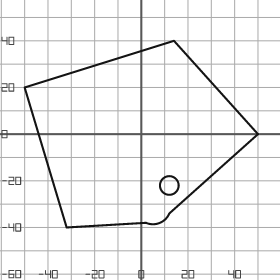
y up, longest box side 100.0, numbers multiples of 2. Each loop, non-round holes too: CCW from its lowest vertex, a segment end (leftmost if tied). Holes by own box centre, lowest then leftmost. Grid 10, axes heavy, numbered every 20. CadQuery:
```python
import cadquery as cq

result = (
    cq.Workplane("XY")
    .moveTo(-32.0, -40.0)
    .lineTo(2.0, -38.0)
    .threePointArc((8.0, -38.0), (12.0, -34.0))
    .lineTo(50.0, 0.0)
    .lineTo(14.0, 40.0)
    .lineTo(-50.0, 20.0)
    .close()
    .moveTo(12.0, -22.0)
    .circle(4.0)
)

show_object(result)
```